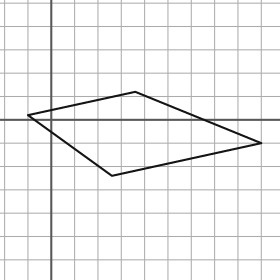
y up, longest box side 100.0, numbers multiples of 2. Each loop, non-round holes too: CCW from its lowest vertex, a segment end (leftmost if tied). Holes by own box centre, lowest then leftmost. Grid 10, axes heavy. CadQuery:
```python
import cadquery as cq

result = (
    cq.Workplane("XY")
    .moveTo(26.0, -24.0)
    .lineTo(90.0, -10.0)
    .lineTo(36.0, 12.0)
    .lineTo(-10.0, 2.0)
    .close()
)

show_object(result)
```